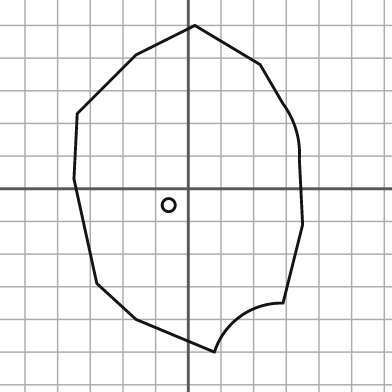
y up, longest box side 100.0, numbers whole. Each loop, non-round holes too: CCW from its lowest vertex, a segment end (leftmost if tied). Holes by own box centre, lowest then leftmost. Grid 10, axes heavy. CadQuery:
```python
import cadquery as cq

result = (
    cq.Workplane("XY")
    .moveTo(8.0, -50.0)
    .threePointArc((16.0, -39.0), (29.0, -35.0))
    .lineTo(35.0, -11.0)
    .lineTo(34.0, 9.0)
    .threePointArc((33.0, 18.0), (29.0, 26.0))
    .lineTo(22.0, 38.0)
    .lineTo(2.0, 50.0)
    .lineTo(-16.0, 41.0)
    .lineTo(-34.0, 23.0)
    .lineTo(-35.0, 3.0)
    .lineTo(-28.0, -29.0)
    .lineTo(-16.0, -40.0)
    .close()
    .moveTo(-6.0, -5.0)
    .circle(2.0)
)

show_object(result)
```